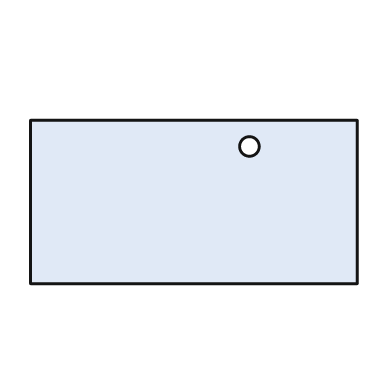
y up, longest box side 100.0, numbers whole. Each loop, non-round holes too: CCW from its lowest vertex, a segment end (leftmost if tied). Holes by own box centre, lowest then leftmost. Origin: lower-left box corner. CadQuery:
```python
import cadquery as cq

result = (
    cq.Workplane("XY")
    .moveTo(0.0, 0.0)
    .lineTo(100.0, 0.0)
    .lineTo(100.0, 50.0)
    .lineTo(0.0, 50.0)
    .close()
    .moveTo(67.0, 42.0)
    .circle(3.0)
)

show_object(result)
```